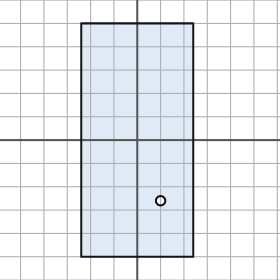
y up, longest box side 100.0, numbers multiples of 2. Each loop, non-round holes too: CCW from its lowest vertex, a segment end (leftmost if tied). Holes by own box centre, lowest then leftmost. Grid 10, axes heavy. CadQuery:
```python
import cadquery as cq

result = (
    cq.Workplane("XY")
    .moveTo(-24.0, -50.0)
    .lineTo(24.0, -50.0)
    .lineTo(24.0, 50.0)
    .lineTo(-24.0, 50.0)
    .close()
    .moveTo(10.0, -26.0)
    .circle(2.0)
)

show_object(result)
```